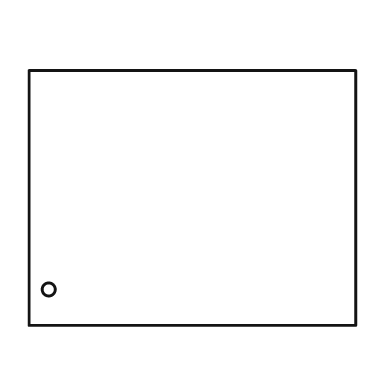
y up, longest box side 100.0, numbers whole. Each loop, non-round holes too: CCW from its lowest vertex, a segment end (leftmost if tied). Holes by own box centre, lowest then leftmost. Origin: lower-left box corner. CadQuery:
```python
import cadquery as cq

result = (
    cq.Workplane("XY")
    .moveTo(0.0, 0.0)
    .lineTo(100.0, 0.0)
    .lineTo(100.0, 78.0)
    .lineTo(0.0, 78.0)
    .close()
    .moveTo(6.0, 11.0)
    .circle(2.0)
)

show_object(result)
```